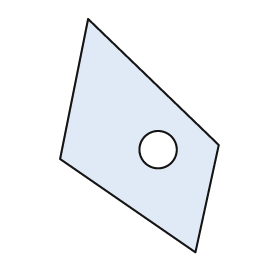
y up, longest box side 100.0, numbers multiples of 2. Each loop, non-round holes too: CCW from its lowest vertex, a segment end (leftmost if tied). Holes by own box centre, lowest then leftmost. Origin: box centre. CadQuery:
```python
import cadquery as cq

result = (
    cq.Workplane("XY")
    .moveTo(24.0, -50.0)
    .lineTo(34.0, -4.0)
    .lineTo(-22.0, 50.0)
    .lineTo(-34.0, -10.0)
    .close()
    .moveTo(8.0, -6.0)
    .circle(8.0)
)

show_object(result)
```